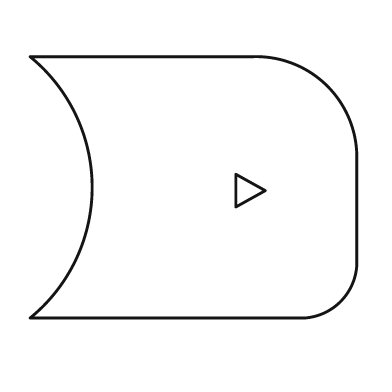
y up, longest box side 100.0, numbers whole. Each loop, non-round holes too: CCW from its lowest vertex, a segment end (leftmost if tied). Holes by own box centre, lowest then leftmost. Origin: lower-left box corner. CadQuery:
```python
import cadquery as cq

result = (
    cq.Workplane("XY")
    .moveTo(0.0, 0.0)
    .lineTo(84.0, 0.0)
    .threePointArc((95.0, 5.0), (100.0, 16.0))
    .lineTo(100.0, 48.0)
    .threePointArc((91.0, 71.0), (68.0, 80.0))
    .lineTo(0.0, 80.0)
    .threePointArc((19.0, 40.0), (0.0, 0.0))
    .close()
    .moveTo(63.0, 34.0)
    .lineTo(72.0, 39.0)
    .lineTo(63.0, 44.0)
    .close()
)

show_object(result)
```